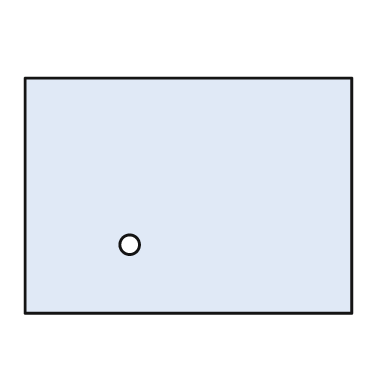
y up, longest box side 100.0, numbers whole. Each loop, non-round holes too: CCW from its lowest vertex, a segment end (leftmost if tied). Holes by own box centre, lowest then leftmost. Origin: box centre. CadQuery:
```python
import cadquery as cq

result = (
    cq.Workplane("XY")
    .moveTo(-50.0, -36.0)
    .lineTo(50.0, -36.0)
    .lineTo(50.0, 36.0)
    .lineTo(-50.0, 36.0)
    .close()
    .moveTo(-18.0, -15.0)
    .circle(3.0)
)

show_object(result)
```